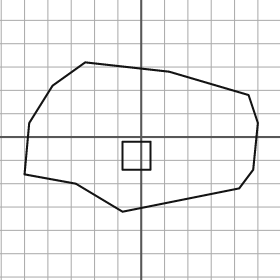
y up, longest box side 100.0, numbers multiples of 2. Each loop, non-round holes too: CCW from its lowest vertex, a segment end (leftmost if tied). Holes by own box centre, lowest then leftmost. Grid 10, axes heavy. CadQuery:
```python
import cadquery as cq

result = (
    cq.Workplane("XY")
    .moveTo(-8.0, -32.0)
    .lineTo(42.0, -22.0)
    .lineTo(48.0, -14.0)
    .lineTo(50.0, 6.0)
    .lineTo(46.0, 18.0)
    .lineTo(12.0, 28.0)
    .lineTo(-24.0, 32.0)
    .lineTo(-38.0, 22.0)
    .lineTo(-48.0, 6.0)
    .lineTo(-50.0, -16.0)
    .lineTo(-28.0, -20.0)
    .close()
    .moveTo(-8.0, -14.0)
    .lineTo(4.0, -14.0)
    .lineTo(4.0, -2.0)
    .lineTo(-8.0, -2.0)
    .close()
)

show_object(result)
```